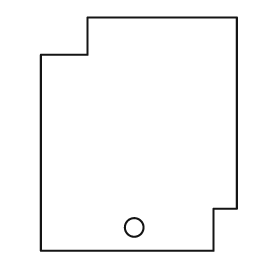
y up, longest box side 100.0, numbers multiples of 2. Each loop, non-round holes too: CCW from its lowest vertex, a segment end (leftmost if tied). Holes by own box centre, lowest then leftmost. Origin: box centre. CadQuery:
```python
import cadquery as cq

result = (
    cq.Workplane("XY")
    .moveTo(-42.0, -50.0)
    .lineTo(32.0, -50.0)
    .lineTo(32.0, -32.0)
    .lineTo(42.0, -32.0)
    .lineTo(42.0, 50.0)
    .lineTo(-22.0, 50.0)
    .lineTo(-22.0, 34.0)
    .lineTo(-42.0, 34.0)
    .close()
    .moveTo(-2.0, -40.0)
    .circle(4.0)
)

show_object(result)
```